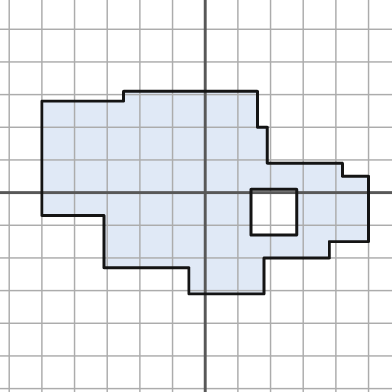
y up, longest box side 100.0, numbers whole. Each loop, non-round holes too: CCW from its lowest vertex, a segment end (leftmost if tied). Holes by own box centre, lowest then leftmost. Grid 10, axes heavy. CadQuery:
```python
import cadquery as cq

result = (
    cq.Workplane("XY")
    .moveTo(-5.0, -31.0)
    .lineTo(18.0, -31.0)
    .lineTo(18.0, -20.0)
    .lineTo(38.0, -20.0)
    .lineTo(38.0, -15.0)
    .lineTo(50.0, -15.0)
    .lineTo(50.0, 5.0)
    .lineTo(42.0, 5.0)
    .lineTo(42.0, 9.0)
    .lineTo(19.0, 9.0)
    .lineTo(19.0, 20.0)
    .lineTo(16.0, 20.0)
    .lineTo(16.0, 31.0)
    .lineTo(-25.0, 31.0)
    .lineTo(-25.0, 28.0)
    .lineTo(-50.0, 28.0)
    .lineTo(-50.0, -7.0)
    .lineTo(-31.0, -7.0)
    .lineTo(-31.0, -23.0)
    .lineTo(-5.0, -23.0)
    .close()
    .moveTo(14.0, -13.0)
    .lineTo(28.0, -13.0)
    .lineTo(28.0, 1.0)
    .lineTo(14.0, 1.0)
    .close()
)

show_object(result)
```